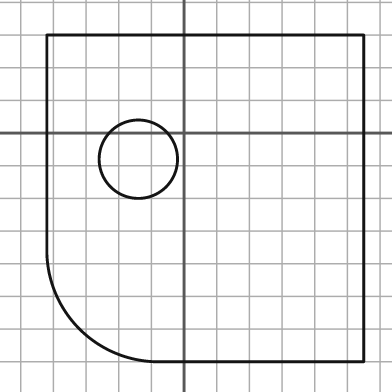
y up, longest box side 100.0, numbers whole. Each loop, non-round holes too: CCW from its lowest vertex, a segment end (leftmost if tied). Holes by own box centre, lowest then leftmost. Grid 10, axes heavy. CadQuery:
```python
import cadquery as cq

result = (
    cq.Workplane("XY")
    .moveTo(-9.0, -70.0)
    .lineTo(55.0, -70.0)
    .lineTo(55.0, 30.0)
    .lineTo(-42.0, 30.0)
    .lineTo(-42.0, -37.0)
    .threePointArc((-32.0, -60.0), (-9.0, -70.0))
    .close()
    .moveTo(-14.0, -8.0)
    .circle(12.0)
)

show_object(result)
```